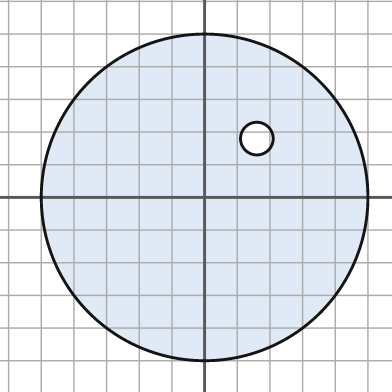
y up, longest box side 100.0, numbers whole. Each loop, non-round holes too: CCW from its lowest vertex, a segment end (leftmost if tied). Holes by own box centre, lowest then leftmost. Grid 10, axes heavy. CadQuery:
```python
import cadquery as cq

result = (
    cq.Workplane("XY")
    .moveTo(0.0, 0.0)
    .circle(50.0)
    .moveTo(16.0, 18.0)
    .circle(5.0)
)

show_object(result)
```